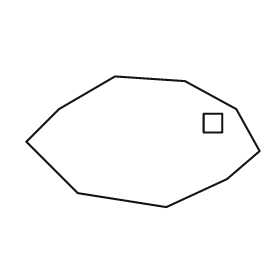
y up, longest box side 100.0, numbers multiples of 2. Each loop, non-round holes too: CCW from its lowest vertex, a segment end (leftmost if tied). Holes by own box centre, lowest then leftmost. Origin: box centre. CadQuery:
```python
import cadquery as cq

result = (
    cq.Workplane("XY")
    .moveTo(10.0, -28.0)
    .lineTo(36.0, -16.0)
    .lineTo(50.0, -4.0)
    .lineTo(40.0, 14.0)
    .lineTo(18.0, 26.0)
    .lineTo(-12.0, 28.0)
    .lineTo(-36.0, 14.0)
    .lineTo(-50.0, 0.0)
    .lineTo(-28.0, -22.0)
    .close()
    .moveTo(26.0, 4.0)
    .lineTo(34.0, 4.0)
    .lineTo(34.0, 12.0)
    .lineTo(26.0, 12.0)
    .close()
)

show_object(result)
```